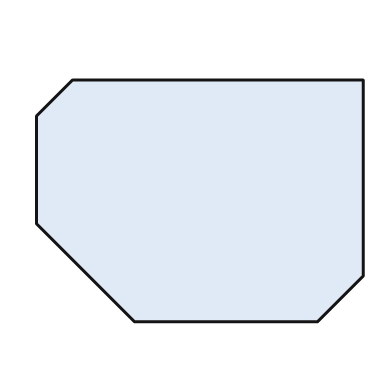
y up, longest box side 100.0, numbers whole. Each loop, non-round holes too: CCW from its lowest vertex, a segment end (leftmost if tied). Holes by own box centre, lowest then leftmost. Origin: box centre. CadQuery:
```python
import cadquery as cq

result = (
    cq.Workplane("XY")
    .moveTo(-20.0, -37.0)
    .lineTo(36.0, -37.0)
    .lineTo(50.0, -23.0)
    .lineTo(50.0, 37.0)
    .lineTo(-39.0, 37.0)
    .lineTo(-50.0, 26.0)
    .lineTo(-50.0, -7.0)
    .close()
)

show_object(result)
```